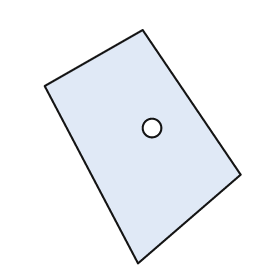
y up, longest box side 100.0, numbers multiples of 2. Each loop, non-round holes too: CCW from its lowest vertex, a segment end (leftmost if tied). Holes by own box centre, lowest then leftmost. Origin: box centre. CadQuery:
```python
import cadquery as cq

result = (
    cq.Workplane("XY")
    .moveTo(-2.0, -50.0)
    .lineTo(42.0, -12.0)
    .lineTo(0.0, 50.0)
    .lineTo(-42.0, 26.0)
    .close()
    .moveTo(4.0, 8.0)
    .circle(4.0)
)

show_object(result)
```